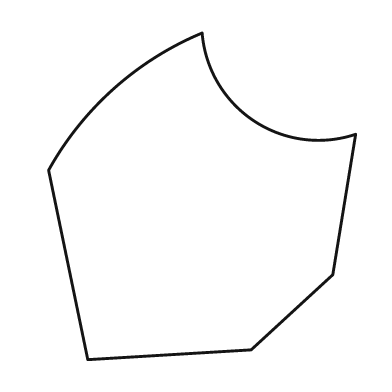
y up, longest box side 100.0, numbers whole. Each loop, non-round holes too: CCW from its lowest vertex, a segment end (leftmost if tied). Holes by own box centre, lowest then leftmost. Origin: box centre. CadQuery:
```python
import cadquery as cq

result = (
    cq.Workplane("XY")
    .moveTo(-35.0, -50.0)
    .lineTo(15.0, -47.0)
    .lineTo(40.0, -24.0)
    .lineTo(47.0, 19.0)
    .threePointArc((16.0, 23.0), (0.0, 50.0))
    .threePointArc((-27.0, 33.0), (-47.0, 8.0))
    .close()
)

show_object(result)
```